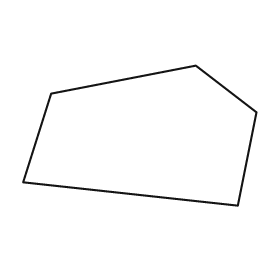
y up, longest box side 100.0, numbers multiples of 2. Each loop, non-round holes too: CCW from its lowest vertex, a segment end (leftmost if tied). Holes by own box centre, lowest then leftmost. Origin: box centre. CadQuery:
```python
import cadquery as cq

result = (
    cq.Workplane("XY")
    .moveTo(42.0, -30.0)
    .lineTo(50.0, 10.0)
    .lineTo(24.0, 30.0)
    .lineTo(-38.0, 18.0)
    .lineTo(-50.0, -20.0)
    .close()
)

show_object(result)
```